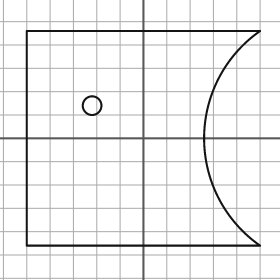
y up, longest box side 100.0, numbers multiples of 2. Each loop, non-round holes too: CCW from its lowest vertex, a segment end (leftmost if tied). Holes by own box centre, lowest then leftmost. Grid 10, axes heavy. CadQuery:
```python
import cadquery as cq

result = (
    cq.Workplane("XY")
    .moveTo(-50.0, -46.0)
    .lineTo(50.0, -46.0)
    .threePointArc((26.0, 0.0), (50.0, 46.0))
    .lineTo(-50.0, 46.0)
    .close()
    .moveTo(-22.0, 14.0)
    .circle(4.0)
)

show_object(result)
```